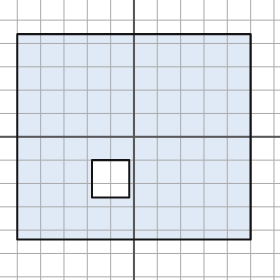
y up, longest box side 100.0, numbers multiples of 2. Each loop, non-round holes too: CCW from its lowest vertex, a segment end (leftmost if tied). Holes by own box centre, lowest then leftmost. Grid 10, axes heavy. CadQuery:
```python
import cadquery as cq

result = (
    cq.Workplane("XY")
    .moveTo(-50.0, -44.0)
    .lineTo(50.0, -44.0)
    .lineTo(50.0, 44.0)
    .lineTo(-50.0, 44.0)
    .close()
    .moveTo(-18.0, -26.0)
    .lineTo(-2.0, -26.0)
    .lineTo(-2.0, -10.0)
    .lineTo(-18.0, -10.0)
    .close()
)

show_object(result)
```